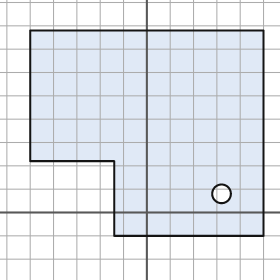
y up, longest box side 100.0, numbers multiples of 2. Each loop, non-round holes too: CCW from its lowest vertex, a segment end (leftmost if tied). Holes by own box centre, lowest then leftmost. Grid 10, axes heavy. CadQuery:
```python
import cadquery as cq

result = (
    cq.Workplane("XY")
    .moveTo(-14.0, -10.0)
    .lineTo(50.0, -10.0)
    .lineTo(50.0, 78.0)
    .lineTo(-50.0, 78.0)
    .lineTo(-50.0, 22.0)
    .lineTo(-14.0, 22.0)
    .close()
    .moveTo(32.0, 8.0)
    .circle(4.0)
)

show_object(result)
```